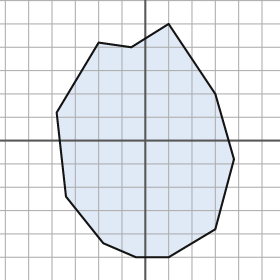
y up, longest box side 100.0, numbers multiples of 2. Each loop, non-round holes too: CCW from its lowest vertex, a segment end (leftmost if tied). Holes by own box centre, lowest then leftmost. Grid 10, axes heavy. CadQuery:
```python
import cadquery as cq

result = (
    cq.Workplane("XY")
    .moveTo(-4.0, -50.0)
    .lineTo(10.0, -50.0)
    .lineTo(30.0, -38.0)
    .lineTo(38.0, -8.0)
    .lineTo(30.0, 20.0)
    .lineTo(10.0, 50.0)
    .lineTo(-6.0, 40.0)
    .lineTo(-20.0, 42.0)
    .lineTo(-38.0, 12.0)
    .lineTo(-34.0, -24.0)
    .lineTo(-18.0, -44.0)
    .close()
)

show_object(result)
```